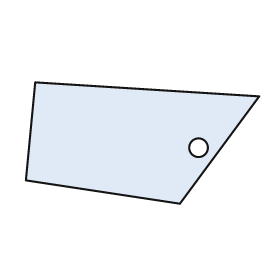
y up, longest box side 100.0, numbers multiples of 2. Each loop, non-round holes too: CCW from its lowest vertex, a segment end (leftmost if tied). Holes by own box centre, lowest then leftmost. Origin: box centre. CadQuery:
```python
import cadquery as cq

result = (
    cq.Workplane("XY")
    .moveTo(16.0, -26.0)
    .lineTo(50.0, 20.0)
    .lineTo(-46.0, 26.0)
    .lineTo(-50.0, -16.0)
    .close()
    .moveTo(24.0, -2.0)
    .circle(4.0)
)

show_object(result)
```